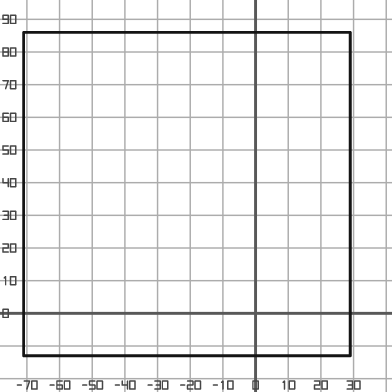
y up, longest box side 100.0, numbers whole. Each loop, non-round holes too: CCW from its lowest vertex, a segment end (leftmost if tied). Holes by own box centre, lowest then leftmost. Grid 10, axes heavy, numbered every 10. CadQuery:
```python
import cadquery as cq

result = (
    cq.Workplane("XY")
    .moveTo(-71.0, -13.0)
    .lineTo(29.0, -13.0)
    .lineTo(29.0, 86.0)
    .lineTo(-71.0, 86.0)
    .close()
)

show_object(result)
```